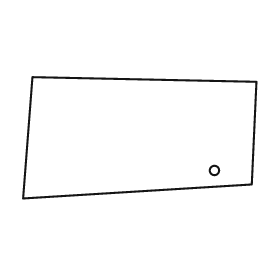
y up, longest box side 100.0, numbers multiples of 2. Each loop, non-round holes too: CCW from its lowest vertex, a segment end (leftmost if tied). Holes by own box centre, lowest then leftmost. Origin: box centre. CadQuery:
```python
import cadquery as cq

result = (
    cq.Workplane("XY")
    .moveTo(-50.0, -26.0)
    .lineTo(48.0, -20.0)
    .lineTo(50.0, 24.0)
    .lineTo(-46.0, 26.0)
    .close()
    .moveTo(32.0, -14.0)
    .circle(2.0)
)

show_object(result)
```